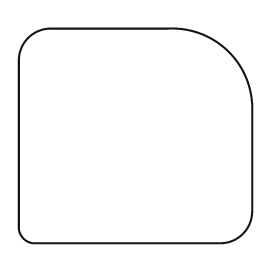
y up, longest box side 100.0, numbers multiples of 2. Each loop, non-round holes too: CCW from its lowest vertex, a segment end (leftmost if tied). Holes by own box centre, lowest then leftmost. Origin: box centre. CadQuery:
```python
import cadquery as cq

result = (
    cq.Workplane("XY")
    .moveTo(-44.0, -46.0)
    .lineTo(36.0, -46.0)
    .threePointArc((46.0, -42.0), (50.0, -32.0))
    .lineTo(50.0, 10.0)
    .threePointArc((40.0, 36.0), (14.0, 46.0))
    .lineTo(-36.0, 46.0)
    .threePointArc((-46.0, 42.0), (-50.0, 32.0))
    .lineTo(-50.0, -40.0)
    .threePointArc((-48.0, -44.0), (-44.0, -46.0))
    .close()
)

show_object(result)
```